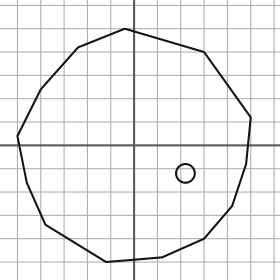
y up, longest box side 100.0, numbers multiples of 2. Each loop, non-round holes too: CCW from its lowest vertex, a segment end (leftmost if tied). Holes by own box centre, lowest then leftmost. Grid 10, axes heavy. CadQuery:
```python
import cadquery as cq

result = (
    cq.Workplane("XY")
    .moveTo(-12.0, -50.0)
    .lineTo(12.0, -48.0)
    .lineTo(30.0, -40.0)
    .lineTo(42.0, -26.0)
    .lineTo(48.0, -8.0)
    .lineTo(50.0, 12.0)
    .lineTo(30.0, 40.0)
    .lineTo(-4.0, 50.0)
    .lineTo(-24.0, 42.0)
    .lineTo(-40.0, 24.0)
    .lineTo(-50.0, 4.0)
    .lineTo(-46.0, -16.0)
    .lineTo(-38.0, -34.0)
    .close()
    .moveTo(22.0, -12.0)
    .circle(4.0)
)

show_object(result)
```